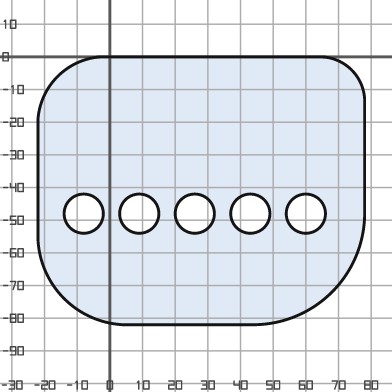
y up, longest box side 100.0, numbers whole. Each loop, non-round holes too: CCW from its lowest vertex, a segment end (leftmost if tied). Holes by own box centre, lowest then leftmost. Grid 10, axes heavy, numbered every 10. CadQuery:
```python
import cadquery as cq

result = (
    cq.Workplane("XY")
    .moveTo(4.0, -82.0)
    .lineTo(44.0, -82.0)
    .threePointArc((68.0, -72.0), (78.0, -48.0))
    .lineTo(78.0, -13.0)
    .threePointArc((74.0, -4.0), (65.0, 0.0))
    .lineTo(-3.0, 0.0)
    .threePointArc((-16.0, -6.0), (-22.0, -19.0))
    .lineTo(-22.0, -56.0)
    .threePointArc((-14.0, -74.0), (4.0, -82.0))
    .close()
    .moveTo(-8.0, -48.0)
    .circle(6.0)
    .moveTo(9.0, -48.0)
    .circle(6.0)
    .moveTo(26.0, -48.0)
    .circle(6.0)
    .moveTo(43.0, -48.0)
    .circle(6.0)
    .moveTo(60.0, -48.0)
    .circle(6.0)
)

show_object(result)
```